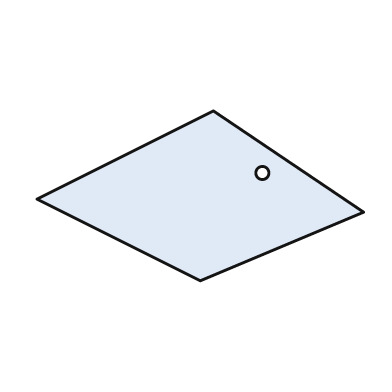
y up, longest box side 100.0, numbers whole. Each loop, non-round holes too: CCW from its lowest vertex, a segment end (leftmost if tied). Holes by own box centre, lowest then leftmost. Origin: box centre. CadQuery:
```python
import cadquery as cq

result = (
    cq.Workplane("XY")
    .moveTo(0.0, -26.0)
    .lineTo(50.0, -5.0)
    .lineTo(4.0, 26.0)
    .lineTo(-50.0, -1.0)
    .close()
    .moveTo(19.0, 7.0)
    .circle(2.0)
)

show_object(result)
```